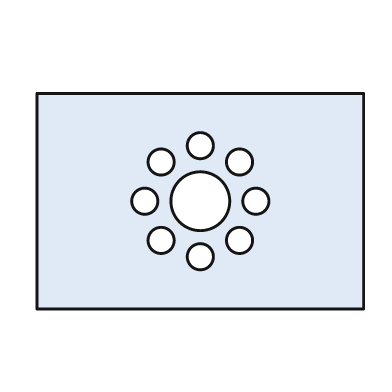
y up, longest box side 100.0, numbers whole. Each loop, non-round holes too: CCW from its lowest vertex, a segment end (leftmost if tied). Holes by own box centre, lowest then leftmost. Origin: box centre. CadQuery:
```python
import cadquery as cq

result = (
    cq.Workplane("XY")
    .moveTo(-50.0, -33.0)
    .lineTo(50.0, -33.0)
    .lineTo(50.0, 33.0)
    .lineTo(-50.0, 33.0)
    .close()
    .moveTo(0.0, -17.0)
    .circle(4.0)
    .moveTo(-12.0, -12.0)
    .circle(4.0)
    .moveTo(12.0, -12.0)
    .circle(4.0)
    .moveTo(-17.0, 0.0)
    .circle(4.0)
    .moveTo(0.0, 0.0)
    .circle(9.0)
    .moveTo(17.0, 0.0)
    .circle(4.0)
    .moveTo(-12.0, 12.0)
    .circle(4.0)
    .moveTo(12.0, 12.0)
    .circle(4.0)
    .moveTo(0.0, 17.0)
    .circle(4.0)
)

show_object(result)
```